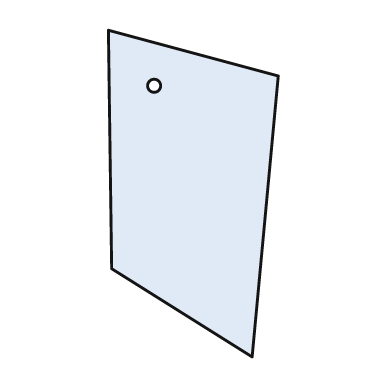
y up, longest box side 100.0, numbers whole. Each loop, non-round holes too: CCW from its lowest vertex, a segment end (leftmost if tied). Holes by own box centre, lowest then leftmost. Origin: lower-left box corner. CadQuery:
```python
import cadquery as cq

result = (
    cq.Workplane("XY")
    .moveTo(44.0, 0.0)
    .lineTo(52.0, 86.0)
    .lineTo(0.0, 100.0)
    .lineTo(1.0, 27.0)
    .close()
    .moveTo(14.0, 83.0)
    .circle(2.0)
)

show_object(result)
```